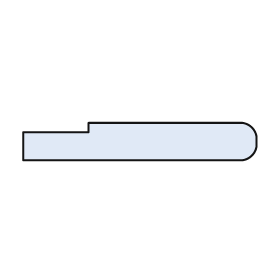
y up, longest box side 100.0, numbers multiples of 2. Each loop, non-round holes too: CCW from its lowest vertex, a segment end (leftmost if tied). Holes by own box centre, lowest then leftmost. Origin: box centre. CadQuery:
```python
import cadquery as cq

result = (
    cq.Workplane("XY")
    .moveTo(-50.0, -8.0)
    .lineTo(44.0, -8.0)
    .threePointArc((48.0, -6.0), (50.0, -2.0))
    .lineTo(50.0, 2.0)
    .threePointArc((48.0, 6.0), (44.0, 8.0))
    .lineTo(-22.0, 8.0)
    .lineTo(-22.0, 4.0)
    .lineTo(-50.0, 4.0)
    .close()
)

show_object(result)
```